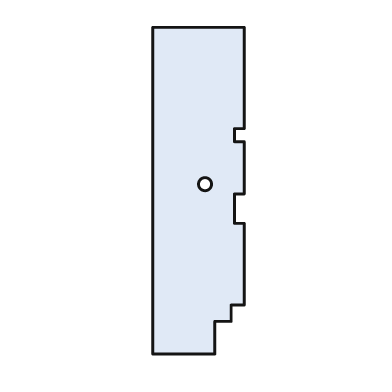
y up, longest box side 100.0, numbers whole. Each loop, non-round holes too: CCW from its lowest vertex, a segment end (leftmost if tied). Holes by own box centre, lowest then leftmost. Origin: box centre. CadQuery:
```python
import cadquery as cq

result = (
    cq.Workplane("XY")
    .moveTo(-14.0, -50.0)
    .lineTo(5.0, -50.0)
    .lineTo(5.0, -40.0)
    .lineTo(10.0, -40.0)
    .lineTo(10.0, -35.0)
    .lineTo(14.0, -35.0)
    .lineTo(14.0, -10.0)
    .lineTo(11.0, -10.0)
    .lineTo(11.0, -1.0)
    .lineTo(14.0, -1.0)
    .lineTo(14.0, 15.0)
    .lineTo(11.0, 15.0)
    .lineTo(11.0, 19.0)
    .lineTo(14.0, 19.0)
    .lineTo(14.0, 50.0)
    .lineTo(-14.0, 50.0)
    .close()
    .moveTo(2.0, 2.0)
    .circle(2.0)
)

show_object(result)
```